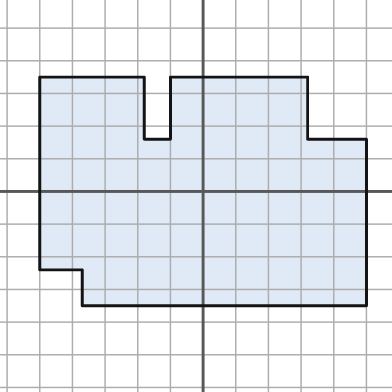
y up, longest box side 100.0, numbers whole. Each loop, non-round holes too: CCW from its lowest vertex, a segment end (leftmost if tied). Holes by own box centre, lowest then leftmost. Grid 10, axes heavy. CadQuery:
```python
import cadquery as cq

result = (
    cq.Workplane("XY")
    .moveTo(-37.0, -35.0)
    .lineTo(50.0, -35.0)
    .lineTo(50.0, 16.0)
    .lineTo(32.0, 16.0)
    .lineTo(32.0, 35.0)
    .lineTo(-10.0, 35.0)
    .lineTo(-10.0, 16.0)
    .lineTo(-18.0, 16.0)
    .lineTo(-18.0, 35.0)
    .lineTo(-50.0, 35.0)
    .lineTo(-50.0, -24.0)
    .lineTo(-37.0, -24.0)
    .close()
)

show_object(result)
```